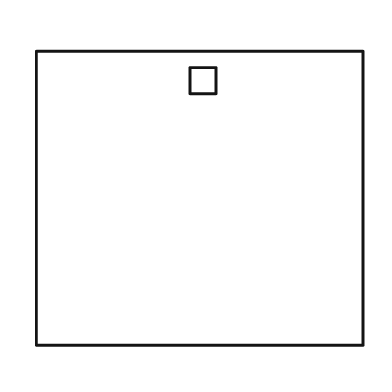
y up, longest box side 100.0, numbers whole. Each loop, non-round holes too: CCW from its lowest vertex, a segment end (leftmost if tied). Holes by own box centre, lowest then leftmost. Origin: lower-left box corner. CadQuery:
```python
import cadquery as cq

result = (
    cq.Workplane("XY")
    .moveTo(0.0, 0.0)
    .lineTo(100.0, 0.0)
    .lineTo(100.0, 90.0)
    .lineTo(0.0, 90.0)
    .close()
    .moveTo(47.0, 77.0)
    .lineTo(55.0, 77.0)
    .lineTo(55.0, 85.0)
    .lineTo(47.0, 85.0)
    .close()
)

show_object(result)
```